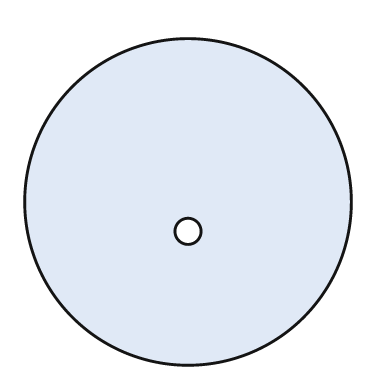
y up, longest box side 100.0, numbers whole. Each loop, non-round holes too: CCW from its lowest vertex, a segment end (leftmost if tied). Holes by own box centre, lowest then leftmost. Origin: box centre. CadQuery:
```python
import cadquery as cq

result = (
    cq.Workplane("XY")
    .moveTo(0.0, 0.0)
    .circle(50.0)
    .moveTo(0.0, -9.0)
    .circle(4.0)
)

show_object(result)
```